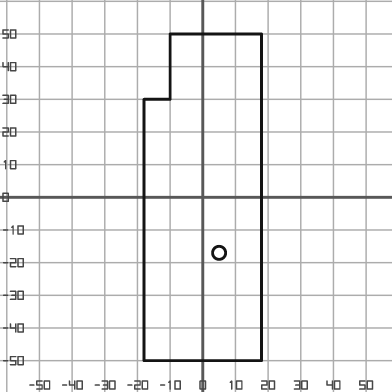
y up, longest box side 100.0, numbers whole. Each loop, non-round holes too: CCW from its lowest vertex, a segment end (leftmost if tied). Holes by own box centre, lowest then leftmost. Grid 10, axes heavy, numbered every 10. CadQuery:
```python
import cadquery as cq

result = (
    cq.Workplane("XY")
    .moveTo(-18.0, -50.0)
    .lineTo(18.0, -50.0)
    .lineTo(18.0, 50.0)
    .lineTo(-10.0, 50.0)
    .lineTo(-10.0, 30.0)
    .lineTo(-18.0, 30.0)
    .close()
    .moveTo(5.0, -17.0)
    .circle(2.0)
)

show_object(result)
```